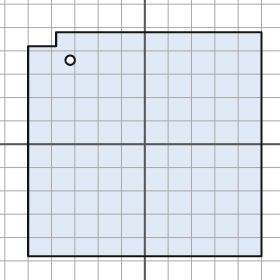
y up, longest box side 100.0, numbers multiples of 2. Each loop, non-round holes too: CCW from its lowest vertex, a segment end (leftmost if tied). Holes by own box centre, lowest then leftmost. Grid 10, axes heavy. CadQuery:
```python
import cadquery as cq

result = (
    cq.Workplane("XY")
    .moveTo(-50.0, -48.0)
    .lineTo(50.0, -48.0)
    .lineTo(50.0, 48.0)
    .lineTo(-38.0, 48.0)
    .lineTo(-38.0, 42.0)
    .lineTo(-50.0, 42.0)
    .close()
    .moveTo(-32.0, 36.0)
    .circle(2.0)
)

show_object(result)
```